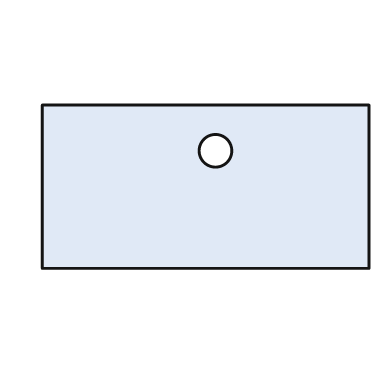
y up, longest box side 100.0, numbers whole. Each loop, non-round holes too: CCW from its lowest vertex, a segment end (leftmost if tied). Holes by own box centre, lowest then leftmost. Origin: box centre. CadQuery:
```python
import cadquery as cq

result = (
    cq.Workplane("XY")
    .moveTo(-50.0, -25.0)
    .lineTo(50.0, -25.0)
    .lineTo(50.0, 25.0)
    .lineTo(-50.0, 25.0)
    .close()
    .moveTo(3.0, 11.0)
    .circle(5.0)
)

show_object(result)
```